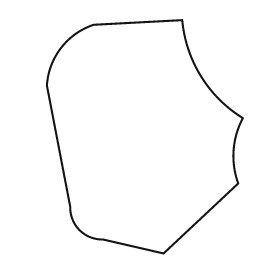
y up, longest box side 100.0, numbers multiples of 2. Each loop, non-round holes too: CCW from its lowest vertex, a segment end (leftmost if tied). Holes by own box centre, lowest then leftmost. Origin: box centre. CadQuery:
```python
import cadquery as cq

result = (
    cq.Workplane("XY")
    .moveTo(8.0, -50.0)
    .lineTo(40.0, -20.0)
    .threePointArc((38.0, -6.0), (42.0, 8.0))
    .threePointArc((24.0, 26.0), (16.0, 50.0))
    .lineTo(-22.0, 48.0)
    .threePointArc((-36.0, 38.0), (-42.0, 22.0))
    .lineTo(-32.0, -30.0)
    .threePointArc((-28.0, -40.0), (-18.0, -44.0))
    .close()
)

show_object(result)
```